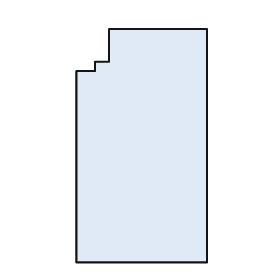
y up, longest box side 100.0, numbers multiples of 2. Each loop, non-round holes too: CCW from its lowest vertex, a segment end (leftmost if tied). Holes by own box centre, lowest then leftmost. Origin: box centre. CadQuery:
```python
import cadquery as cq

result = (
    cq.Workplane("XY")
    .moveTo(-28.0, -50.0)
    .lineTo(28.0, -50.0)
    .lineTo(28.0, 50.0)
    .lineTo(-14.0, 50.0)
    .lineTo(-14.0, 36.0)
    .lineTo(-20.0, 36.0)
    .lineTo(-20.0, 32.0)
    .lineTo(-28.0, 32.0)
    .close()
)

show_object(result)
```